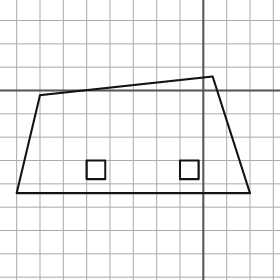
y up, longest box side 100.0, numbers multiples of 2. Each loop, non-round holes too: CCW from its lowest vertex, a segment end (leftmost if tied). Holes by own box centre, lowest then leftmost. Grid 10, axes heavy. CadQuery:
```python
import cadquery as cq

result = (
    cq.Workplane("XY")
    .moveTo(-80.0, -44.0)
    .lineTo(20.0, -44.0)
    .lineTo(4.0, 6.0)
    .lineTo(-70.0, -2.0)
    .close()
    .moveTo(-50.0, -38.0)
    .lineTo(-42.0, -38.0)
    .lineTo(-42.0, -30.0)
    .lineTo(-50.0, -30.0)
    .close()
    .moveTo(-10.0, -38.0)
    .lineTo(-2.0, -38.0)
    .lineTo(-2.0, -30.0)
    .lineTo(-10.0, -30.0)
    .close()
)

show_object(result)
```